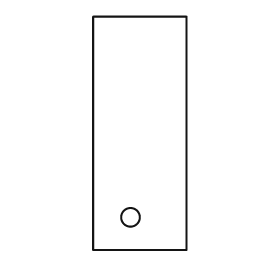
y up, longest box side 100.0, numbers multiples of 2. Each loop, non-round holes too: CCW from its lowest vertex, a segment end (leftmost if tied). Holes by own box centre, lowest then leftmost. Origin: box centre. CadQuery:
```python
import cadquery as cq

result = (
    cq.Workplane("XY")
    .moveTo(-20.0, -50.0)
    .lineTo(20.0, -50.0)
    .lineTo(20.0, 50.0)
    .lineTo(-20.0, 50.0)
    .close()
    .moveTo(-4.0, -36.0)
    .circle(4.0)
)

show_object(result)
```